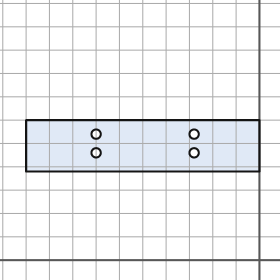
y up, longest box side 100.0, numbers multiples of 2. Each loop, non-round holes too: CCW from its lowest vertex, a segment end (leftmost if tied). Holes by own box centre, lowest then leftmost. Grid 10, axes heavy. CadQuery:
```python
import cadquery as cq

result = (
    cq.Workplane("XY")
    .moveTo(-100.0, 38.0)
    .lineTo(0.0, 38.0)
    .lineTo(0.0, 60.0)
    .lineTo(-100.0, 60.0)
    .close()
    .moveTo(-70.0, 46.0)
    .circle(2.0)
    .moveTo(-28.0, 46.0)
    .circle(2.0)
    .moveTo(-70.0, 54.0)
    .circle(2.0)
    .moveTo(-28.0, 54.0)
    .circle(2.0)
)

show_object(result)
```